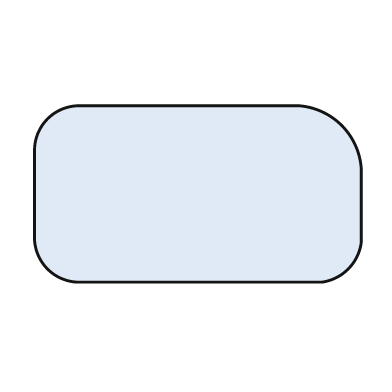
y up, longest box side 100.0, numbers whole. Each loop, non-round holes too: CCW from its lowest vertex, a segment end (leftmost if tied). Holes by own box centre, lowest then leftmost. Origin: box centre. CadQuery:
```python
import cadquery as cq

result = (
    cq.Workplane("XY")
    .moveTo(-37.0, -27.0)
    .lineTo(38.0, -27.0)
    .threePointArc((46.0, -23.0), (50.0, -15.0))
    .lineTo(50.0, 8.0)
    .threePointArc((44.0, 21.0), (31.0, 27.0))
    .lineTo(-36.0, 27.0)
    .threePointArc((-46.0, 23.0), (-50.0, 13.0))
    .lineTo(-50.0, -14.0)
    .threePointArc((-46.0, -23.0), (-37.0, -27.0))
    .close()
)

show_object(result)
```